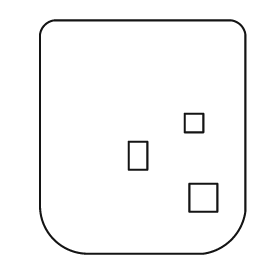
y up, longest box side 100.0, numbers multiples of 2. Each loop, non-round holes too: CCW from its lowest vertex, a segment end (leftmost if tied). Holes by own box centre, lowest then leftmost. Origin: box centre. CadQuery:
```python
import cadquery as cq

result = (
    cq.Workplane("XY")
    .moveTo(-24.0, -50.0)
    .lineTo(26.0, -50.0)
    .threePointArc((38.0, -44.0), (44.0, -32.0))
    .lineTo(44.0, 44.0)
    .threePointArc((42.0, 48.0), (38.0, 50.0))
    .lineTo(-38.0, 50.0)
    .threePointArc((-42.0, 48.0), (-44.0, 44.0))
    .lineTo(-44.0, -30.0)
    .threePointArc((-38.0, -44.0), (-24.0, -50.0))
    .close()
    .moveTo(20.0, -32.0)
    .lineTo(32.0, -32.0)
    .lineTo(32.0, -20.0)
    .lineTo(20.0, -20.0)
    .close()
    .moveTo(-6.0, -14.0)
    .lineTo(2.0, -14.0)
    .lineTo(2.0, -2.0)
    .lineTo(-6.0, -2.0)
    .close()
    .moveTo(18.0, 2.0)
    .lineTo(26.0, 2.0)
    .lineTo(26.0, 10.0)
    .lineTo(18.0, 10.0)
    .close()
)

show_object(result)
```